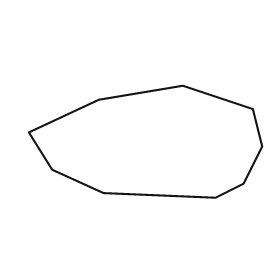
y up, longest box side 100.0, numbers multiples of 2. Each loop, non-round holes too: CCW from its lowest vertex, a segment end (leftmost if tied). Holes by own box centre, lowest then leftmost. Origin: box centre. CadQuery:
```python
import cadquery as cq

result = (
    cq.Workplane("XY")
    .moveTo(30.0, -24.0)
    .lineTo(42.0, -18.0)
    .lineTo(50.0, -2.0)
    .lineTo(46.0, 14.0)
    .lineTo(16.0, 24.0)
    .lineTo(-20.0, 18.0)
    .lineTo(-50.0, 4.0)
    .lineTo(-40.0, -12.0)
    .lineTo(-18.0, -22.0)
    .close()
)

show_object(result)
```